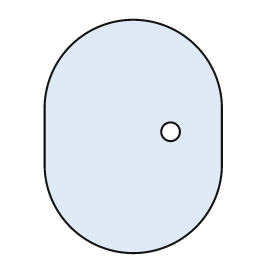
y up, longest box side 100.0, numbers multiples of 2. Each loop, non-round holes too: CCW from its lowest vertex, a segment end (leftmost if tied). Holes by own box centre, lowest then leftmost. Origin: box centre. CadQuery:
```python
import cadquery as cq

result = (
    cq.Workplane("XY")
    .moveTo(-38.0, -12.0)
    .threePointArc((0.0, -50.0), (38.0, -12.0))
    .lineTo(38.0, 12.0)
    .threePointArc((0.0, 50.0), (-38.0, 12.0))
    .close()
    .moveTo(16.0, 2.0)
    .circle(4.0)
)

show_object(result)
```